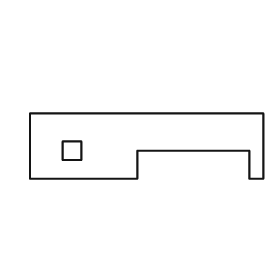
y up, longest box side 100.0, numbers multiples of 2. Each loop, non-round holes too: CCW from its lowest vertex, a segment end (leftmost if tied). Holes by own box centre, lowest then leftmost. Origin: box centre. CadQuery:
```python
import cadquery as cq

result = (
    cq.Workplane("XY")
    .moveTo(-50.0, -14.0)
    .lineTo(-4.0, -14.0)
    .lineTo(-4.0, -2.0)
    .lineTo(44.0, -2.0)
    .lineTo(44.0, -14.0)
    .lineTo(50.0, -14.0)
    .lineTo(50.0, 14.0)
    .lineTo(-50.0, 14.0)
    .close()
    .moveTo(-36.0, -6.0)
    .lineTo(-28.0, -6.0)
    .lineTo(-28.0, 2.0)
    .lineTo(-36.0, 2.0)
    .close()
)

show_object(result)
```